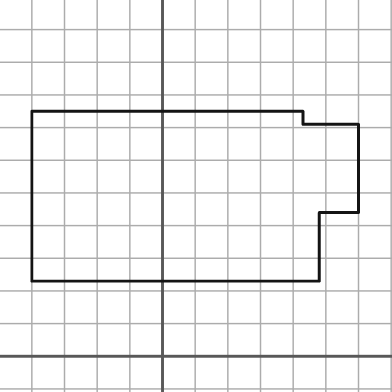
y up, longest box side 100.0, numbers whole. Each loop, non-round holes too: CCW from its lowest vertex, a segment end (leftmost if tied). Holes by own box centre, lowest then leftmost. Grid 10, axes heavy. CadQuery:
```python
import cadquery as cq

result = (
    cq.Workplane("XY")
    .moveTo(-40.0, 23.0)
    .lineTo(48.0, 23.0)
    .lineTo(48.0, 44.0)
    .lineTo(60.0, 44.0)
    .lineTo(60.0, 71.0)
    .lineTo(43.0, 71.0)
    .lineTo(43.0, 75.0)
    .lineTo(-40.0, 75.0)
    .close()
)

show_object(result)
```